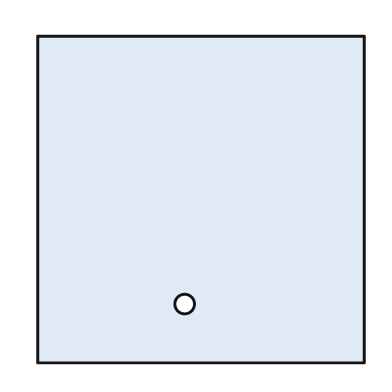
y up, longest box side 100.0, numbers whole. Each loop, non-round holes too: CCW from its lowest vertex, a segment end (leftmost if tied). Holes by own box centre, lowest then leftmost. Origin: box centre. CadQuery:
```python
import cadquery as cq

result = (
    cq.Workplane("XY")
    .moveTo(-50.0, -50.0)
    .lineTo(50.0, -50.0)
    .lineTo(50.0, 50.0)
    .lineTo(-50.0, 50.0)
    .close()
    .moveTo(-5.0, -32.0)
    .circle(3.0)
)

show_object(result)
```